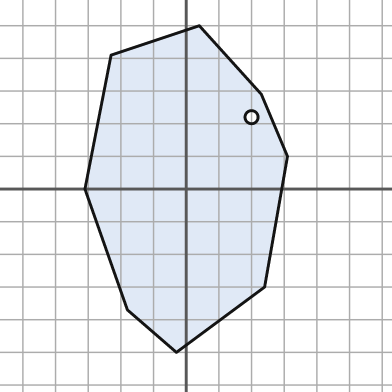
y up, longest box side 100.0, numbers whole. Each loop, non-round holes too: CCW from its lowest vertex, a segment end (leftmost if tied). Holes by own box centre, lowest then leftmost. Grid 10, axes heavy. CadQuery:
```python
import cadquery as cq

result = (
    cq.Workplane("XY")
    .moveTo(-3.0, -50.0)
    .lineTo(24.0, -30.0)
    .lineTo(31.0, 10.0)
    .lineTo(23.0, 29.0)
    .lineTo(4.0, 50.0)
    .lineTo(-23.0, 41.0)
    .lineTo(-31.0, 0.0)
    .lineTo(-18.0, -37.0)
    .close()
    .moveTo(20.0, 22.0)
    .circle(2.0)
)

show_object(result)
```